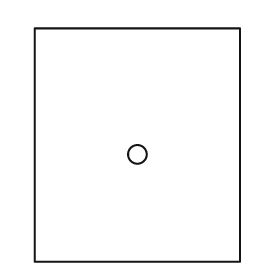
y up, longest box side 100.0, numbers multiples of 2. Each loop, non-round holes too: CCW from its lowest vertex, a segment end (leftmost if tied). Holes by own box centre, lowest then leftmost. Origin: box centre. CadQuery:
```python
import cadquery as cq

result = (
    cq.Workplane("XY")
    .moveTo(-44.0, -50.0)
    .lineTo(44.0, -50.0)
    .lineTo(44.0, 50.0)
    .lineTo(-44.0, 50.0)
    .close()
    .moveTo(0.0, -4.0)
    .circle(4.0)
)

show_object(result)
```